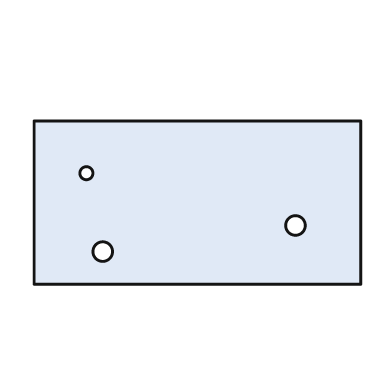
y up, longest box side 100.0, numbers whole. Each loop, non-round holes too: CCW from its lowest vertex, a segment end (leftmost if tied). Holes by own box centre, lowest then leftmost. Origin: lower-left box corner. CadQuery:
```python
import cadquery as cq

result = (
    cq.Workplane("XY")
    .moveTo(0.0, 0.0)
    .lineTo(100.0, 0.0)
    .lineTo(100.0, 50.0)
    .lineTo(0.0, 50.0)
    .close()
    .moveTo(21.0, 10.0)
    .circle(3.0)
    .moveTo(80.0, 18.0)
    .circle(3.0)
    .moveTo(16.0, 34.0)
    .circle(2.0)
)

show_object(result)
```